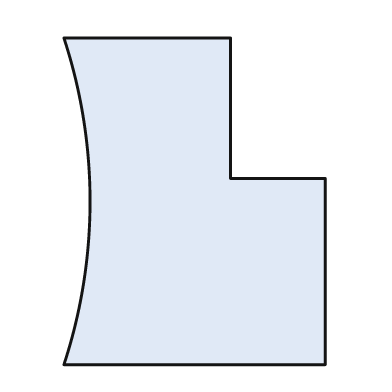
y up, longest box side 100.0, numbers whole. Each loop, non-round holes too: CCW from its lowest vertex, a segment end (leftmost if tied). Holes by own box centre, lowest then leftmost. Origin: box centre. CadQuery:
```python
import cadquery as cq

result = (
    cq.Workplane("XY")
    .moveTo(-40.0, -50.0)
    .lineTo(40.0, -50.0)
    .lineTo(40.0, 7.0)
    .lineTo(11.0, 7.0)
    .lineTo(11.0, 50.0)
    .lineTo(-40.0, 50.0)
    .threePointArc((-32.0, 0.0), (-40.0, -50.0))
    .close()
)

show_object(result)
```